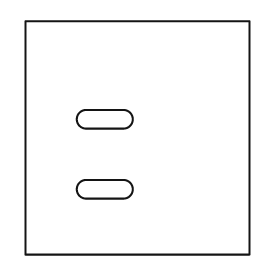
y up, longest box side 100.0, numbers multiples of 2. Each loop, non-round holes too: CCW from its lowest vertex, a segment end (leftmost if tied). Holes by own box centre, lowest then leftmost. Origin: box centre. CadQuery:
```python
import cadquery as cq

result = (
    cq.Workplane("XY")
    .moveTo(-48.0, -50.0)
    .lineTo(48.0, -50.0)
    .lineTo(48.0, 50.0)
    .lineTo(-48.0, 50.0)
    .close()
    .moveTo(-22.0, -26.0)
    .lineTo(-6.0, -26.0)
    .threePointArc((-2.0, -22.0), (-6.0, -18.0))
    .lineTo(-22.0, -18.0)
    .threePointArc((-26.0, -22.0), (-22.0, -26.0))
    .close()
    .moveTo(-22.0, 4.0)
    .lineTo(-6.0, 4.0)
    .threePointArc((-2.0, 8.0), (-6.0, 12.0))
    .lineTo(-22.0, 12.0)
    .threePointArc((-26.0, 8.0), (-22.0, 4.0))
    .close()
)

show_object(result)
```